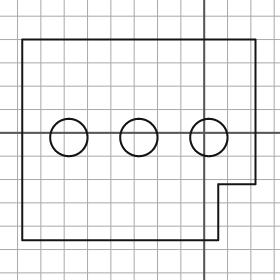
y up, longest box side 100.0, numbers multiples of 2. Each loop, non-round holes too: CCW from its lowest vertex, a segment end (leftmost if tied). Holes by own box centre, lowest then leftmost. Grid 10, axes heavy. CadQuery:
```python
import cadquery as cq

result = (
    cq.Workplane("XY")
    .moveTo(-78.0, -46.0)
    .lineTo(6.0, -46.0)
    .lineTo(6.0, -22.0)
    .lineTo(22.0, -22.0)
    .lineTo(22.0, 40.0)
    .lineTo(-78.0, 40.0)
    .close()
    .moveTo(-58.0, -2.0)
    .circle(8.0)
    .moveTo(-28.0, -2.0)
    .circle(8.0)
    .moveTo(2.0, -2.0)
    .circle(8.0)
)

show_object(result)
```